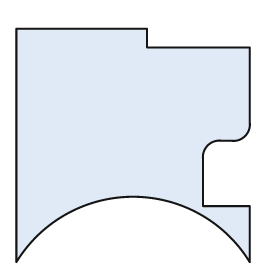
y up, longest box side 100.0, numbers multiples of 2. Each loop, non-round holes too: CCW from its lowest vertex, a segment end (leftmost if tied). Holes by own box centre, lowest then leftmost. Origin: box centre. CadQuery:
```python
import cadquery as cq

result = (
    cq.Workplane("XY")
    .moveTo(-50.0, -50.0)
    .threePointArc((0.0, -22.0), (50.0, -50.0))
    .lineTo(50.0, -26.0)
    .lineTo(30.0, -26.0)
    .lineTo(30.0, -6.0)
    .threePointArc((32.0, 0.0), (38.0, 2.0))
    .lineTo(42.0, 2.0)
    .threePointArc((48.0, 4.0), (50.0, 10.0))
    .lineTo(50.0, 42.0)
    .lineTo(6.0, 42.0)
    .lineTo(6.0, 50.0)
    .lineTo(-50.0, 50.0)
    .close()
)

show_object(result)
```